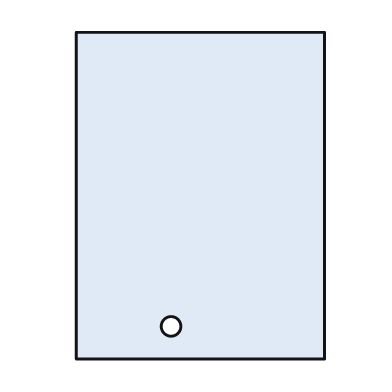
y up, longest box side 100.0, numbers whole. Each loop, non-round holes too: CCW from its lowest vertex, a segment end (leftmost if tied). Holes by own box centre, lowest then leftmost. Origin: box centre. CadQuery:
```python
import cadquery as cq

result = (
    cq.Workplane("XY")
    .moveTo(-38.0, -50.0)
    .lineTo(38.0, -50.0)
    .lineTo(38.0, 50.0)
    .lineTo(-38.0, 50.0)
    .close()
    .moveTo(-9.0, -40.0)
    .circle(3.0)
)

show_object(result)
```